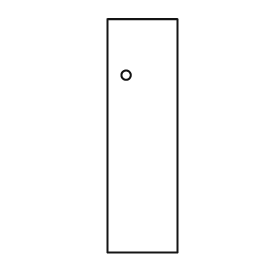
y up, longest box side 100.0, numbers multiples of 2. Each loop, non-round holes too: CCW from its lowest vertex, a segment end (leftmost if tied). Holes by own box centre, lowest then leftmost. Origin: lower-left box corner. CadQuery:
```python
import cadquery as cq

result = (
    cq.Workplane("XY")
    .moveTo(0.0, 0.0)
    .lineTo(30.0, 0.0)
    .lineTo(30.0, 100.0)
    .lineTo(0.0, 100.0)
    .close()
    .moveTo(8.0, 76.0)
    .circle(2.0)
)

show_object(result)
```